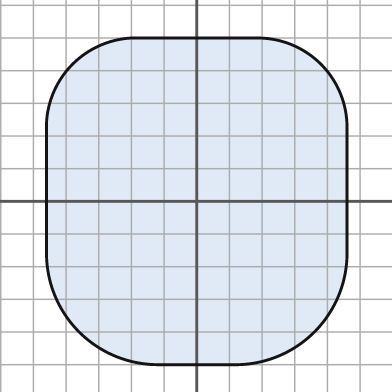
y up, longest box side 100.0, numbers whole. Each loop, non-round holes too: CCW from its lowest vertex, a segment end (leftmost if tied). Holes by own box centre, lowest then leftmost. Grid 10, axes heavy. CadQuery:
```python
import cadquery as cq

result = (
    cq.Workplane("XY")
    .moveTo(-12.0, -50.0)
    .lineTo(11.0, -50.0)
    .threePointArc((36.0, -40.0), (46.0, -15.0))
    .lineTo(46.0, 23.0)
    .threePointArc((38.0, 42.0), (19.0, 50.0))
    .lineTo(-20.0, 50.0)
    .threePointArc((-38.0, 42.0), (-46.0, 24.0))
    .lineTo(-46.0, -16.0)
    .threePointArc((-36.0, -40.0), (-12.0, -50.0))
    .close()
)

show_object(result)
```